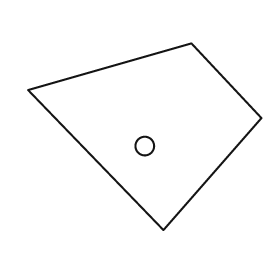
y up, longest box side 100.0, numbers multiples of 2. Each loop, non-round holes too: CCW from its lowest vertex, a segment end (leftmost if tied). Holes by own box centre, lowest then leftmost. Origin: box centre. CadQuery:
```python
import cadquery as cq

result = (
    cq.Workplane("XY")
    .moveTo(8.0, -40.0)
    .lineTo(50.0, 8.0)
    .lineTo(20.0, 40.0)
    .lineTo(-50.0, 20.0)
    .close()
    .moveTo(0.0, -4.0)
    .circle(4.0)
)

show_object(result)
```